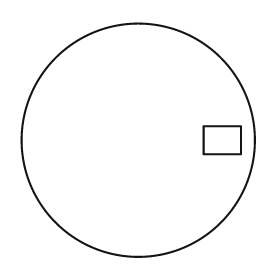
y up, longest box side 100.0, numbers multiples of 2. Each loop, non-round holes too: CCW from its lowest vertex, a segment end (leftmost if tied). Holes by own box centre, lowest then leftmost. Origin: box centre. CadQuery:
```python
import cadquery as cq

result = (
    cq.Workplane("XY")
    .moveTo(0.0, 0.0)
    .circle(50.0)
    .moveTo(28.0, -6.0)
    .lineTo(44.0, -6.0)
    .lineTo(44.0, 6.0)
    .lineTo(28.0, 6.0)
    .close()
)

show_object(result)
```